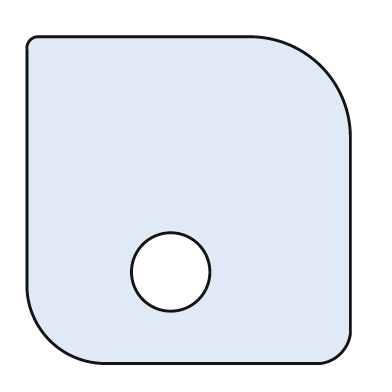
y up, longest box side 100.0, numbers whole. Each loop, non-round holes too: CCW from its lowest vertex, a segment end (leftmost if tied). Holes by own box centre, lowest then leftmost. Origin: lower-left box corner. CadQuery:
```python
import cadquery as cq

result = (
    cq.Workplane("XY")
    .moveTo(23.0, 0.0)
    .lineTo(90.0, 0.0)
    .threePointArc((96.0, 3.0), (99.0, 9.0))
    .lineTo(99.0, 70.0)
    .threePointArc((90.0, 91.0), (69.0, 100.0))
    .lineTo(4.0, 100.0)
    .threePointArc((1.0, 99.0), (0.0, 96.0))
    .lineTo(0.0, 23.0)
    .threePointArc((7.0, 7.0), (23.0, 0.0))
    .close()
    .moveTo(44.0, 28.0)
    .circle(12.0)
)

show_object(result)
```